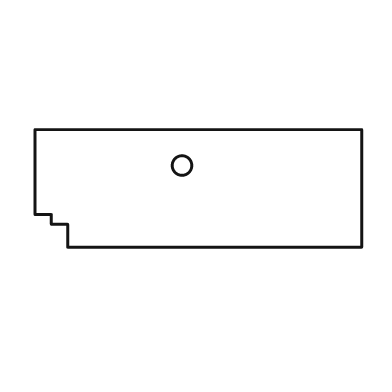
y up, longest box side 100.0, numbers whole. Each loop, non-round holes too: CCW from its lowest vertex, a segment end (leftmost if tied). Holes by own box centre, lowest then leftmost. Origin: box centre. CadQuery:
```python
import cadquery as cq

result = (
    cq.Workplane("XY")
    .moveTo(-40.0, -18.0)
    .lineTo(50.0, -18.0)
    .lineTo(50.0, 18.0)
    .lineTo(-50.0, 18.0)
    .lineTo(-50.0, -8.0)
    .lineTo(-45.0, -8.0)
    .lineTo(-45.0, -11.0)
    .lineTo(-40.0, -11.0)
    .close()
    .moveTo(-5.0, 7.0)
    .circle(3.0)
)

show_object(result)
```